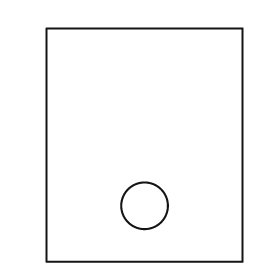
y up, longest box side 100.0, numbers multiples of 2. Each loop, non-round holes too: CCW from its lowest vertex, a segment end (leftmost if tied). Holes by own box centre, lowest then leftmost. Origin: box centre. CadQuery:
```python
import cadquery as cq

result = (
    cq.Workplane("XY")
    .moveTo(-42.0, -50.0)
    .lineTo(42.0, -50.0)
    .lineTo(42.0, 50.0)
    .lineTo(-42.0, 50.0)
    .close()
    .moveTo(0.0, -26.0)
    .circle(10.0)
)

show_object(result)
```